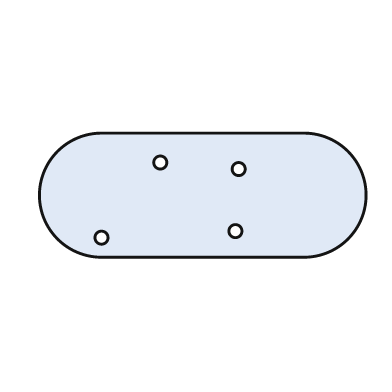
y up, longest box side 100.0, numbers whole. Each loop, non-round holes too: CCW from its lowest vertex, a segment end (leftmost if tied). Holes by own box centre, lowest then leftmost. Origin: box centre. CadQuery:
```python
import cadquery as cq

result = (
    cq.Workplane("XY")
    .moveTo(-31.0, -19.0)
    .lineTo(31.0, -19.0)
    .threePointArc((50.0, 0.0), (31.0, 19.0))
    .lineTo(-31.0, 19.0)
    .threePointArc((-50.0, 0.0), (-31.0, -19.0))
    .close()
    .moveTo(-31.0, -13.0)
    .circle(2.0)
    .moveTo(10.0, -11.0)
    .circle(2.0)
    .moveTo(11.0, 8.0)
    .circle(2.0)
    .moveTo(-13.0, 10.0)
    .circle(2.0)
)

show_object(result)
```